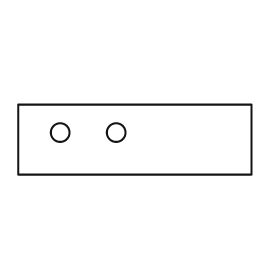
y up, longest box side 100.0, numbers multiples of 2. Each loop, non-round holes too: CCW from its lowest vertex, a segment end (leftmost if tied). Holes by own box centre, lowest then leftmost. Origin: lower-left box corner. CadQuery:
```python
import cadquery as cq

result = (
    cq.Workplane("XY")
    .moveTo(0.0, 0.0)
    .lineTo(100.0, 0.0)
    .lineTo(100.0, 30.0)
    .lineTo(0.0, 30.0)
    .close()
    .moveTo(18.0, 18.0)
    .circle(4.0)
    .moveTo(42.0, 18.0)
    .circle(4.0)
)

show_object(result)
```